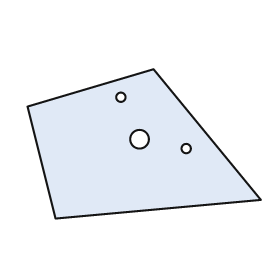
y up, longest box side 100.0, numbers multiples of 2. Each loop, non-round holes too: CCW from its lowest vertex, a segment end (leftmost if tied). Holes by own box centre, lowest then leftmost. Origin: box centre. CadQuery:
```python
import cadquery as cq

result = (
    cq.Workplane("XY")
    .moveTo(-38.0, -32.0)
    .lineTo(50.0, -24.0)
    .lineTo(4.0, 32.0)
    .lineTo(-50.0, 16.0)
    .close()
    .moveTo(18.0, -2.0)
    .circle(2.0)
    .moveTo(-2.0, 2.0)
    .circle(4.0)
    .moveTo(-10.0, 20.0)
    .circle(2.0)
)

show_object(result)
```